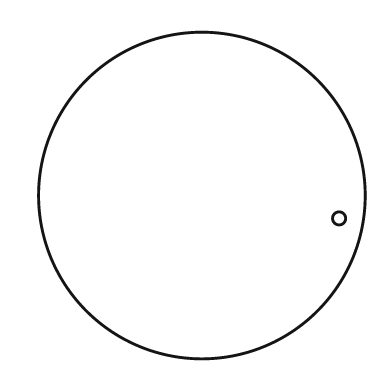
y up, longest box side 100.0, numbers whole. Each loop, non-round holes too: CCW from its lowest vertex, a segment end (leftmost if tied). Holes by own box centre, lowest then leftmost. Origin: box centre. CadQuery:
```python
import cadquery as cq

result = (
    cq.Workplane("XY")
    .moveTo(0.0, 0.0)
    .circle(50.0)
    .moveTo(42.0, -7.0)
    .circle(2.0)
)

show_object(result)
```